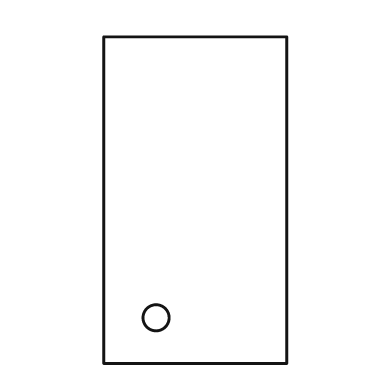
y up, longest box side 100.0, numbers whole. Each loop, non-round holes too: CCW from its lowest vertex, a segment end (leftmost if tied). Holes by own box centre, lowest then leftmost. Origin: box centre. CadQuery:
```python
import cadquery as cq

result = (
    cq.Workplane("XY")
    .moveTo(-28.0, -50.0)
    .lineTo(28.0, -50.0)
    .lineTo(28.0, 50.0)
    .lineTo(-28.0, 50.0)
    .close()
    .moveTo(-12.0, -36.0)
    .circle(4.0)
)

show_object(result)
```